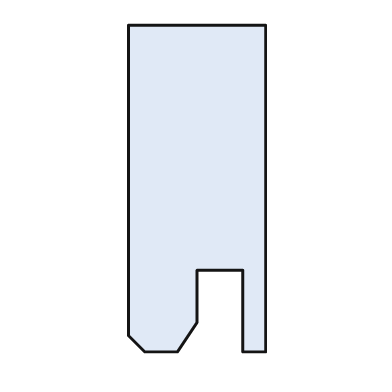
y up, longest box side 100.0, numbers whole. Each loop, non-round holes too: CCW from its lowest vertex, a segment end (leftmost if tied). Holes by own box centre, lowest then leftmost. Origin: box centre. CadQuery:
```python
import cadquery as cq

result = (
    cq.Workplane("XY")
    .moveTo(-16.0, -50.0)
    .lineTo(-6.0, -50.0)
    .lineTo(0.0, -41.0)
    .lineTo(0.0, -25.0)
    .lineTo(14.0, -25.0)
    .lineTo(14.0, -50.0)
    .lineTo(21.0, -50.0)
    .lineTo(21.0, 50.0)
    .lineTo(-21.0, 50.0)
    .lineTo(-21.0, -45.0)
    .close()
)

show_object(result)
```